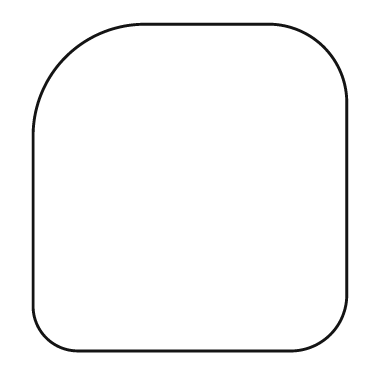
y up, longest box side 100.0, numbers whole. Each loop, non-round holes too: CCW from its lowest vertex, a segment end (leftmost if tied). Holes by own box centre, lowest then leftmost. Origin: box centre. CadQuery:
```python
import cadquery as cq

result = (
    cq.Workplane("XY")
    .moveTo(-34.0, -50.0)
    .lineTo(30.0, -50.0)
    .threePointArc((43.0, -45.0), (48.0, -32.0))
    .lineTo(48.0, 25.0)
    .threePointArc((41.0, 43.0), (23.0, 50.0))
    .lineTo(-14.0, 50.0)
    .threePointArc((-38.0, 40.0), (-48.0, 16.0))
    .lineTo(-48.0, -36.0)
    .threePointArc((-44.0, -46.0), (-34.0, -50.0))
    .close()
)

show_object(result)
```